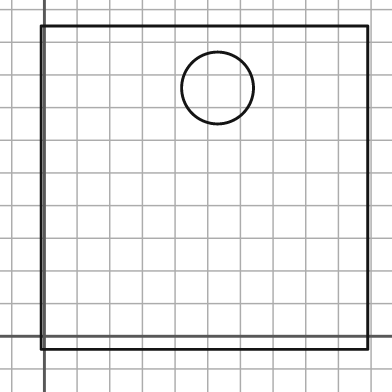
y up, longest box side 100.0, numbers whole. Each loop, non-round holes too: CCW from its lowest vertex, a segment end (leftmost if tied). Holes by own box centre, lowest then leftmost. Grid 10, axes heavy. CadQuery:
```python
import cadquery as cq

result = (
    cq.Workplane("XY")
    .moveTo(-1.0, -4.0)
    .lineTo(99.0, -4.0)
    .lineTo(99.0, 95.0)
    .lineTo(-1.0, 95.0)
    .close()
    .moveTo(53.0, 76.0)
    .circle(11.0)
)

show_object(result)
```